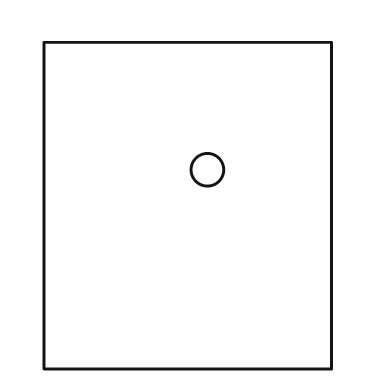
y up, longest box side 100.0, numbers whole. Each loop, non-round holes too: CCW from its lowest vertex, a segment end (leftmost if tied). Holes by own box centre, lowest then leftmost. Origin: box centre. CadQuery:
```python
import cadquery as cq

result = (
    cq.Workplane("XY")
    .moveTo(-44.0, -50.0)
    .lineTo(44.0, -50.0)
    .lineTo(44.0, 50.0)
    .lineTo(-44.0, 50.0)
    .close()
    .moveTo(6.0, 11.0)
    .circle(5.0)
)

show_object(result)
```